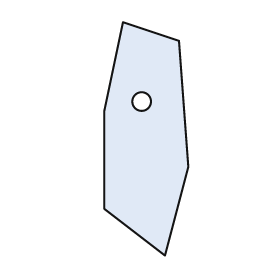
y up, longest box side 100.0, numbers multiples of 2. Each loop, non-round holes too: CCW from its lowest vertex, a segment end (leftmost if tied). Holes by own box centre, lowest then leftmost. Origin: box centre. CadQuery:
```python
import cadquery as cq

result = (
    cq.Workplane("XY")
    .moveTo(8.0, -50.0)
    .lineTo(18.0, -12.0)
    .lineTo(14.0, 42.0)
    .lineTo(-10.0, 50.0)
    .lineTo(-18.0, 12.0)
    .lineTo(-18.0, -30.0)
    .close()
    .moveTo(-2.0, 16.0)
    .circle(4.0)
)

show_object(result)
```